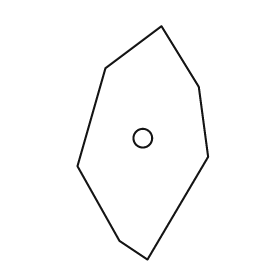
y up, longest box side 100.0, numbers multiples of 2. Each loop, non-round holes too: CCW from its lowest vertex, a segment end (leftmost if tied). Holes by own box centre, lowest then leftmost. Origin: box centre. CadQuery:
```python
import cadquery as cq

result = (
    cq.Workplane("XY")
    .moveTo(2.0, -50.0)
    .lineTo(28.0, -6.0)
    .lineTo(24.0, 24.0)
    .lineTo(8.0, 50.0)
    .lineTo(-16.0, 32.0)
    .lineTo(-28.0, -10.0)
    .lineTo(-10.0, -42.0)
    .close()
    .moveTo(0.0, 2.0)
    .circle(4.0)
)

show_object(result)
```